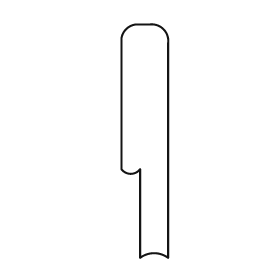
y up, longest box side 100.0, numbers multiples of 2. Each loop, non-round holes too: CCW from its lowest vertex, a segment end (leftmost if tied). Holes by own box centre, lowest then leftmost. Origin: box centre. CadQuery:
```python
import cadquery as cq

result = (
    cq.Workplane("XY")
    .moveTo(-2.0, -50.0)
    .threePointArc((4.0, -48.0), (10.0, -50.0))
    .lineTo(10.0, 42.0)
    .threePointArc((8.0, 48.0), (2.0, 50.0))
    .lineTo(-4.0, 50.0)
    .threePointArc((-8.0, 48.0), (-10.0, 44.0))
    .lineTo(-10.0, -12.0)
    .threePointArc((-6.0, -14.0), (-2.0, -12.0))
    .close()
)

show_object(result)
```